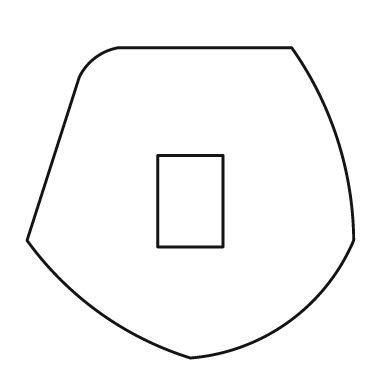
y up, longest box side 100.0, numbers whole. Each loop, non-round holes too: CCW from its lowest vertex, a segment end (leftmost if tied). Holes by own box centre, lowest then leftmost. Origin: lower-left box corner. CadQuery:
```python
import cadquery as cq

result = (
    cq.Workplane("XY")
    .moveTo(50.0, 0.0)
    .threePointArc((80.0, 11.0), (100.0, 36.0))
    .threePointArc((95.0, 67.0), (81.0, 95.0))
    .lineTo(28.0, 95.0)
    .threePointArc((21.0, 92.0), (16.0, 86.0))
    .lineTo(0.0, 36.0)
    .threePointArc((22.0, 14.0), (50.0, 0.0))
    .close()
    .moveTo(40.0, 34.0)
    .lineTo(60.0, 34.0)
    .lineTo(60.0, 62.0)
    .lineTo(40.0, 62.0)
    .close()
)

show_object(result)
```